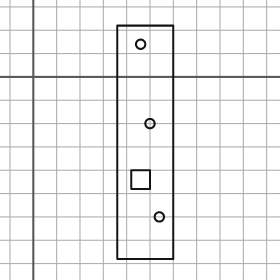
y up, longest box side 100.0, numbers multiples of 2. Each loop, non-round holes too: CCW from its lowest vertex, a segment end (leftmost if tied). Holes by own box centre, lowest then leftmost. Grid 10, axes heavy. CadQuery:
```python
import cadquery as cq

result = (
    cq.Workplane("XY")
    .moveTo(36.0, -78.0)
    .lineTo(60.0, -78.0)
    .lineTo(60.0, 22.0)
    .lineTo(36.0, 22.0)
    .close()
    .moveTo(54.0, -60.0)
    .circle(2.0)
    .moveTo(42.0, -48.0)
    .lineTo(50.0, -48.0)
    .lineTo(50.0, -40.0)
    .lineTo(42.0, -40.0)
    .close()
    .moveTo(50.0, -20.0)
    .circle(2.0)
    .moveTo(46.0, 14.0)
    .circle(2.0)
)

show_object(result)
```